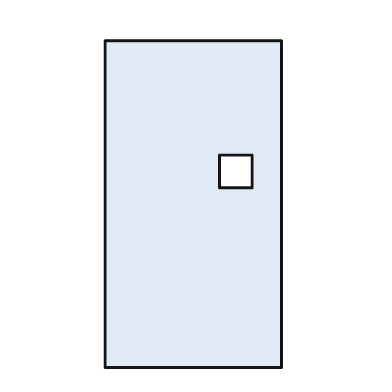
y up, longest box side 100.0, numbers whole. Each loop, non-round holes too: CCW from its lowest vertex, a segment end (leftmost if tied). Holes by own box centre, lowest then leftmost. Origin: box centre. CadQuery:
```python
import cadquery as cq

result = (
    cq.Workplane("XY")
    .moveTo(-27.0, -50.0)
    .lineTo(27.0, -50.0)
    .lineTo(27.0, 50.0)
    .lineTo(-27.0, 50.0)
    .close()
    .moveTo(8.0, 5.0)
    .lineTo(18.0, 5.0)
    .lineTo(18.0, 15.0)
    .lineTo(8.0, 15.0)
    .close()
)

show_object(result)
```